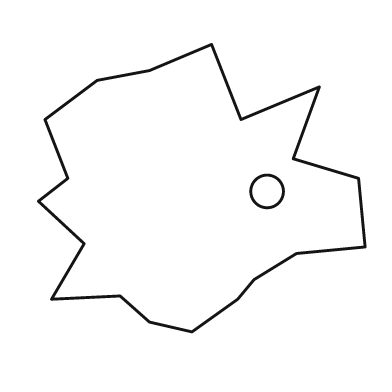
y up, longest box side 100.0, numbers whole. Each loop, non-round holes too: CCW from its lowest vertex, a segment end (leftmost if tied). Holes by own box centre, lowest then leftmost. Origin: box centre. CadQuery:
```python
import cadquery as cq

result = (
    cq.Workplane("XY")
    .moveTo(-3.0, -44.0)
    .lineTo(11.0, -34.0)
    .lineTo(16.0, -28.0)
    .lineTo(29.0, -20.0)
    .lineTo(50.0, -18.0)
    .lineTo(48.0, 3.0)
    .lineTo(28.0, 9.0)
    .lineTo(36.0, 31.0)
    .lineTo(12.0, 21.0)
    .lineTo(3.0, 44.0)
    .lineTo(-16.0, 36.0)
    .lineTo(-32.0, 33.0)
    .lineTo(-48.0, 21.0)
    .lineTo(-41.0, 3.0)
    .lineTo(-50.0, -4.0)
    .lineTo(-36.0, -17.0)
    .lineTo(-46.0, -34.0)
    .lineTo(-25.0, -33.0)
    .lineTo(-16.0, -41.0)
    .close()
    .moveTo(20.0, -1.0)
    .circle(5.0)
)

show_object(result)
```